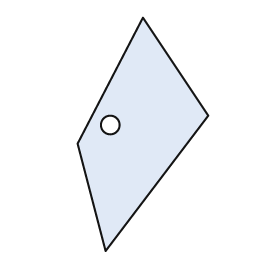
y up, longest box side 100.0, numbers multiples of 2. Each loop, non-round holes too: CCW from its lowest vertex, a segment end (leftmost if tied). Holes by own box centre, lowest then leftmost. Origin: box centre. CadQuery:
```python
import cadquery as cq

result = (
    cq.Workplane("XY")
    .moveTo(-16.0, -50.0)
    .lineTo(28.0, 8.0)
    .lineTo(0.0, 50.0)
    .lineTo(-28.0, -4.0)
    .close()
    .moveTo(-14.0, 4.0)
    .circle(4.0)
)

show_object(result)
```